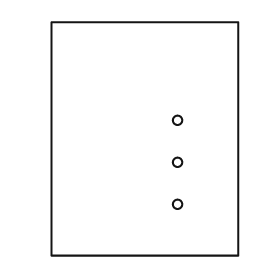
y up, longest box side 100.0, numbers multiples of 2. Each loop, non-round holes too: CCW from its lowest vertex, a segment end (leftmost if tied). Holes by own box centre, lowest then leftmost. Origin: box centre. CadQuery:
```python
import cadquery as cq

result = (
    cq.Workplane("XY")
    .moveTo(-40.0, -50.0)
    .lineTo(40.0, -50.0)
    .lineTo(40.0, 50.0)
    .lineTo(-40.0, 50.0)
    .close()
    .moveTo(14.0, -28.0)
    .circle(2.0)
    .moveTo(14.0, -10.0)
    .circle(2.0)
    .moveTo(14.0, 8.0)
    .circle(2.0)
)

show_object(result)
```